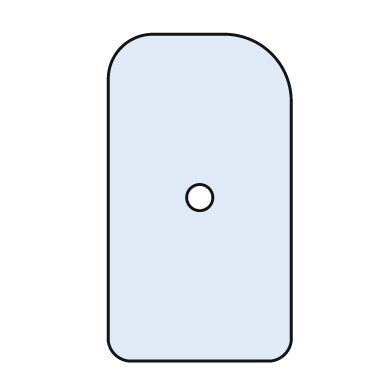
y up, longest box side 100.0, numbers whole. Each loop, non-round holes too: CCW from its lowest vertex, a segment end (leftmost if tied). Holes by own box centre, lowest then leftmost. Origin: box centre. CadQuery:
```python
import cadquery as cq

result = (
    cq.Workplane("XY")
    .moveTo(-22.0, -50.0)
    .lineTo(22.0, -50.0)
    .threePointArc((26.0, -48.0), (28.0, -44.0))
    .lineTo(28.0, 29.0)
    .threePointArc((22.0, 44.0), (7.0, 50.0))
    .lineTo(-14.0, 50.0)
    .threePointArc((-24.0, 46.0), (-28.0, 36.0))
    .lineTo(-28.0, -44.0)
    .threePointArc((-26.0, -48.0), (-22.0, -50.0))
    .close()
    .moveTo(0.0, 0.0)
    .circle(4.0)
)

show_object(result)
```